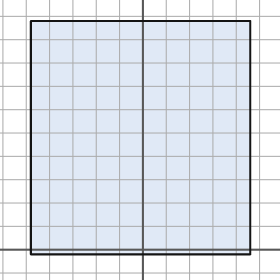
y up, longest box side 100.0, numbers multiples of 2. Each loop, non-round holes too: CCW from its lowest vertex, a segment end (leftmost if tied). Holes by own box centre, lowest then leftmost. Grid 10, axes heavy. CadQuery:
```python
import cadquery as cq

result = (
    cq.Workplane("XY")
    .moveTo(-48.0, -2.0)
    .lineTo(46.0, -2.0)
    .lineTo(46.0, 98.0)
    .lineTo(-48.0, 98.0)
    .close()
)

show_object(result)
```